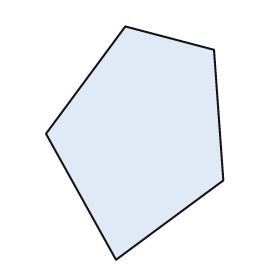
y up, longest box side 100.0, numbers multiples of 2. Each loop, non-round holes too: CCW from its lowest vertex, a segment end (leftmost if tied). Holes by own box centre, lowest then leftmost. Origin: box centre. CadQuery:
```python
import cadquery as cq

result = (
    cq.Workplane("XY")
    .moveTo(-8.0, -50.0)
    .lineTo(38.0, -16.0)
    .lineTo(34.0, 40.0)
    .lineTo(-4.0, 50.0)
    .lineTo(-38.0, 4.0)
    .close()
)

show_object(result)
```